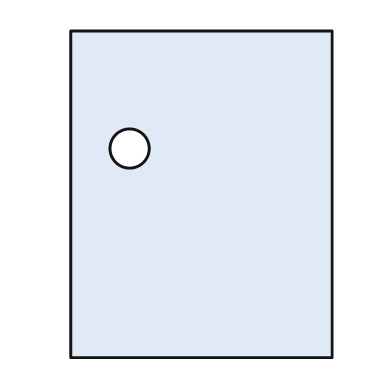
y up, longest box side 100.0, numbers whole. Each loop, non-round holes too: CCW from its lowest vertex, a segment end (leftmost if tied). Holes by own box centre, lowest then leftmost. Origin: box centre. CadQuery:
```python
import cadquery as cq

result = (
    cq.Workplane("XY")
    .moveTo(-40.0, -50.0)
    .lineTo(40.0, -50.0)
    .lineTo(40.0, 50.0)
    .lineTo(-40.0, 50.0)
    .close()
    .moveTo(-22.0, 14.0)
    .circle(6.0)
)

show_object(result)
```